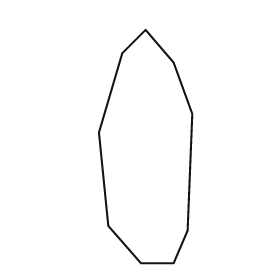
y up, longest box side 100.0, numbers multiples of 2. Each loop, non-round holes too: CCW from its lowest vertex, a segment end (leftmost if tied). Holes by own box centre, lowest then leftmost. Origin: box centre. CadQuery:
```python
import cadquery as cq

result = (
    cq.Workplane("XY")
    .moveTo(-2.0, -50.0)
    .lineTo(12.0, -50.0)
    .lineTo(18.0, -36.0)
    .lineTo(20.0, 14.0)
    .lineTo(12.0, 36.0)
    .lineTo(0.0, 50.0)
    .lineTo(-10.0, 40.0)
    .lineTo(-20.0, 6.0)
    .lineTo(-16.0, -34.0)
    .close()
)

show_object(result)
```